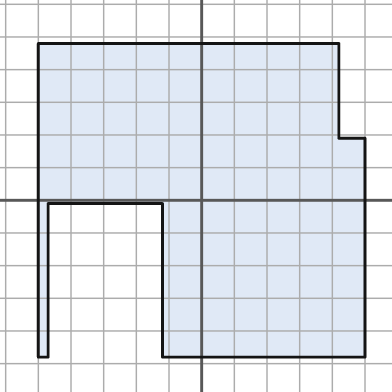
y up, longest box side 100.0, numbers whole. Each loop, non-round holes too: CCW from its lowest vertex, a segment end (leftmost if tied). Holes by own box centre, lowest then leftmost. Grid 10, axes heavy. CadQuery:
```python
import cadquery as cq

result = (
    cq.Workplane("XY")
    .moveTo(-50.0, -48.0)
    .lineTo(-47.0, -48.0)
    .lineTo(-47.0, -1.0)
    .lineTo(-12.0, -1.0)
    .lineTo(-12.0, -48.0)
    .lineTo(50.0, -48.0)
    .lineTo(50.0, 19.0)
    .lineTo(42.0, 19.0)
    .lineTo(42.0, 48.0)
    .lineTo(-50.0, 48.0)
    .close()
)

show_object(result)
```